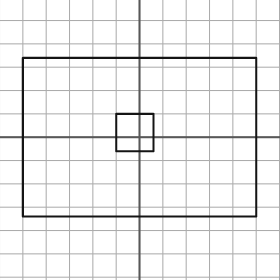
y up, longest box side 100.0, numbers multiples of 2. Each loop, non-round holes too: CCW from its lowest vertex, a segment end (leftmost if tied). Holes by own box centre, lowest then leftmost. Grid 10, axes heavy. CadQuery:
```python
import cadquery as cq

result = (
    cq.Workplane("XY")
    .moveTo(-50.0, -34.0)
    .lineTo(50.0, -34.0)
    .lineTo(50.0, 34.0)
    .lineTo(-50.0, 34.0)
    .close()
    .moveTo(-10.0, -6.0)
    .lineTo(6.0, -6.0)
    .lineTo(6.0, 10.0)
    .lineTo(-10.0, 10.0)
    .close()
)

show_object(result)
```